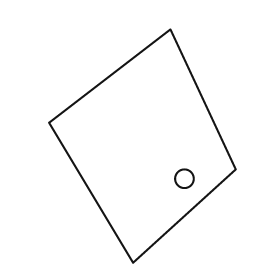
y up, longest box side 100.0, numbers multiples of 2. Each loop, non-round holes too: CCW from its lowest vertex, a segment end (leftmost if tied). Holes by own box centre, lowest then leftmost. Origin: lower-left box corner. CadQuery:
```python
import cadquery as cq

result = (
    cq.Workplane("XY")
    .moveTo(36.0, 0.0)
    .lineTo(80.0, 40.0)
    .lineTo(52.0, 100.0)
    .lineTo(0.0, 60.0)
    .close()
    .moveTo(58.0, 36.0)
    .circle(4.0)
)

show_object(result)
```